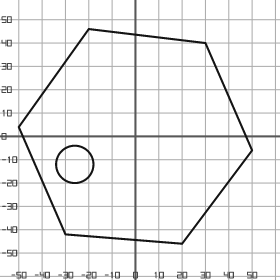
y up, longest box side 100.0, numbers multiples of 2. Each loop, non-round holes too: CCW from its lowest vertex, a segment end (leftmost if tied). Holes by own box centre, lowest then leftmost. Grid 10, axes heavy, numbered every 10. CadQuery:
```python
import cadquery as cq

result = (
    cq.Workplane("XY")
    .moveTo(20.0, -46.0)
    .lineTo(50.0, -6.0)
    .lineTo(30.0, 40.0)
    .lineTo(-20.0, 46.0)
    .lineTo(-50.0, 4.0)
    .lineTo(-30.0, -42.0)
    .close()
    .moveTo(-26.0, -12.0)
    .circle(8.0)
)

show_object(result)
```